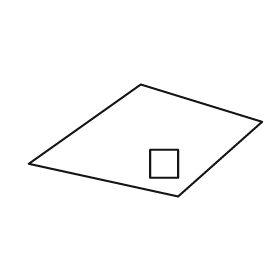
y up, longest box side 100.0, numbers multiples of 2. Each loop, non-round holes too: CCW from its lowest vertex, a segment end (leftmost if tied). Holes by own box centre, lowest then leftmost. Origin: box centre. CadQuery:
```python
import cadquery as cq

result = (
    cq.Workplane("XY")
    .moveTo(14.0, -24.0)
    .lineTo(50.0, 8.0)
    .lineTo(-2.0, 24.0)
    .lineTo(-50.0, -10.0)
    .close()
    .moveTo(2.0, -16.0)
    .lineTo(14.0, -16.0)
    .lineTo(14.0, -4.0)
    .lineTo(2.0, -4.0)
    .close()
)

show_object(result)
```